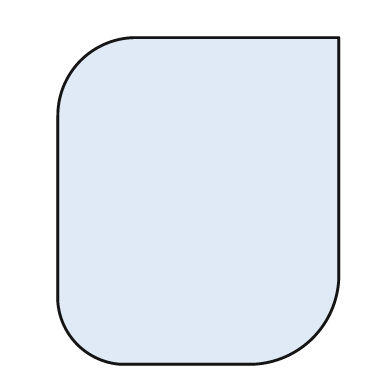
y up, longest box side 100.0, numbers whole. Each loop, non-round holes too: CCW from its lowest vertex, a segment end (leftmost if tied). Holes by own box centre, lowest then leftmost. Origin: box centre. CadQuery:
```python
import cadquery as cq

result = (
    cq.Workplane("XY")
    .moveTo(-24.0, -50.0)
    .lineTo(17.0, -50.0)
    .threePointArc((35.0, -42.0), (43.0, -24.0))
    .lineTo(43.0, 50.0)
    .lineTo(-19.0, 50.0)
    .threePointArc((-36.0, 43.0), (-43.0, 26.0))
    .lineTo(-43.0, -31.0)
    .threePointArc((-37.0, -44.0), (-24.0, -50.0))
    .close()
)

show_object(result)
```